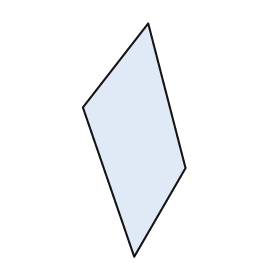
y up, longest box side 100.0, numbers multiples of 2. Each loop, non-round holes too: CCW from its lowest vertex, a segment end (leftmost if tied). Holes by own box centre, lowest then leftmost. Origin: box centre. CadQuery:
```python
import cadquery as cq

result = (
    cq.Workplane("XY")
    .moveTo(0.0, -50.0)
    .lineTo(22.0, -12.0)
    .lineTo(6.0, 50.0)
    .lineTo(-22.0, 14.0)
    .close()
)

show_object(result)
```